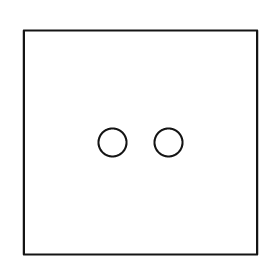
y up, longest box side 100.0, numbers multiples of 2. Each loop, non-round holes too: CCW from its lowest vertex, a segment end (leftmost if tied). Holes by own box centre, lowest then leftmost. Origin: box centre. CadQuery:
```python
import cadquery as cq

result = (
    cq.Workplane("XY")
    .moveTo(-50.0, -48.0)
    .lineTo(50.0, -48.0)
    .lineTo(50.0, 48.0)
    .lineTo(-50.0, 48.0)
    .close()
    .moveTo(-12.0, 0.0)
    .circle(6.0)
    .moveTo(12.0, 0.0)
    .circle(6.0)
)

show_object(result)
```